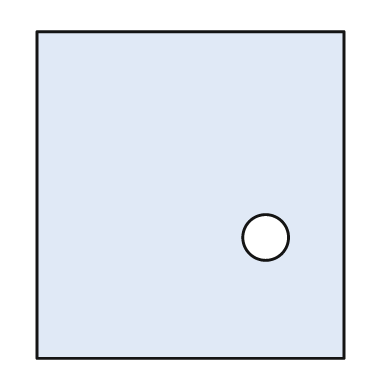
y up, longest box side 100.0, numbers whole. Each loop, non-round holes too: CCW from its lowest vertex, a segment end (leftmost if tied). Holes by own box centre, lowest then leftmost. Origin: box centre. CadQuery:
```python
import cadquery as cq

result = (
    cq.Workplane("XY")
    .moveTo(-47.0, -50.0)
    .lineTo(47.0, -50.0)
    .lineTo(47.0, 50.0)
    .lineTo(-47.0, 50.0)
    .close()
    .moveTo(23.0, -13.0)
    .circle(7.0)
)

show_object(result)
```